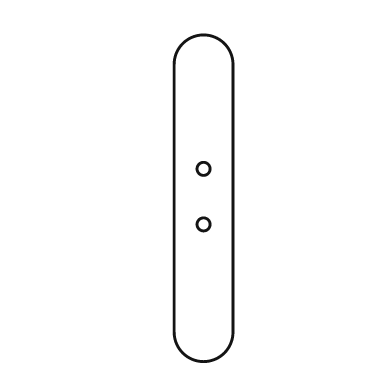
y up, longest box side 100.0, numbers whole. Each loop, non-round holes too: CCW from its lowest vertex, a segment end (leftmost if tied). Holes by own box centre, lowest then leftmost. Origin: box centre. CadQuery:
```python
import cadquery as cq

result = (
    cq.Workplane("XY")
    .moveTo(-9.0, -41.0)
    .threePointArc((0.0, -50.0), (9.0, -41.0))
    .lineTo(9.0, 41.0)
    .threePointArc((0.0, 50.0), (-9.0, 41.0))
    .close()
    .moveTo(0.0, -8.0)
    .circle(2.0)
    .moveTo(0.0, 9.0)
    .circle(2.0)
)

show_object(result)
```